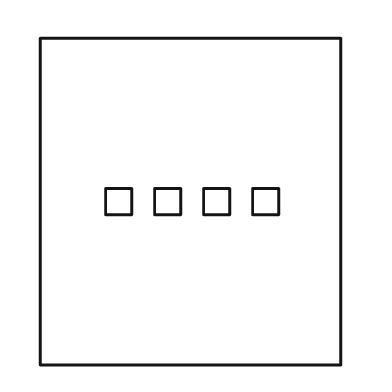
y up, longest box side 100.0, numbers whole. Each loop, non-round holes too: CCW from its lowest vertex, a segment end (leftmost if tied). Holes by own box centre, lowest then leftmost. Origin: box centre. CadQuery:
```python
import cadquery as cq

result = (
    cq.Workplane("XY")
    .moveTo(-46.0, -50.0)
    .lineTo(46.0, -50.0)
    .lineTo(46.0, 50.0)
    .lineTo(-46.0, 50.0)
    .close()
    .moveTo(-26.0, -4.0)
    .lineTo(-18.0, -4.0)
    .lineTo(-18.0, 4.0)
    .lineTo(-26.0, 4.0)
    .close()
    .moveTo(-11.0, -4.0)
    .lineTo(-3.0, -4.0)
    .lineTo(-3.0, 4.0)
    .lineTo(-11.0, 4.0)
    .close()
    .moveTo(4.0, -4.0)
    .lineTo(12.0, -4.0)
    .lineTo(12.0, 4.0)
    .lineTo(4.0, 4.0)
    .close()
    .moveTo(19.0, -4.0)
    .lineTo(27.0, -4.0)
    .lineTo(27.0, 4.0)
    .lineTo(19.0, 4.0)
    .close()
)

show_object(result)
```